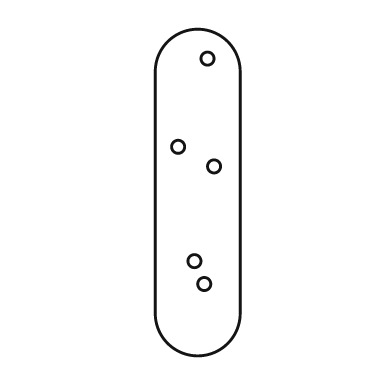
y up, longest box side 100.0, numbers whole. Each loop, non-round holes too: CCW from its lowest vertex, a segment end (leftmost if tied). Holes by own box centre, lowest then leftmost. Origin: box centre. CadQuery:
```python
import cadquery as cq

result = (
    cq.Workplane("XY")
    .moveTo(-13.0, -37.0)
    .threePointArc((0.0, -50.0), (13.0, -37.0))
    .lineTo(13.0, 37.0)
    .threePointArc((0.0, 50.0), (-13.0, 37.0))
    .close()
    .moveTo(2.0, -28.0)
    .circle(2.0)
    .moveTo(-1.0, -21.0)
    .circle(2.0)
    .moveTo(5.0, 8.0)
    .circle(2.0)
    .moveTo(-6.0, 14.0)
    .circle(2.0)
    .moveTo(3.0, 41.0)
    .circle(2.0)
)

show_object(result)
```